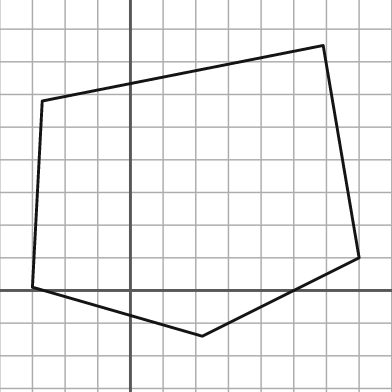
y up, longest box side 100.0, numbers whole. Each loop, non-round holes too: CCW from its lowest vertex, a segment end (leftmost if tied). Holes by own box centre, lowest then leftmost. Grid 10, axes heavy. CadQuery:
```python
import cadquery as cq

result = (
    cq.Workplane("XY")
    .moveTo(22.0, -14.0)
    .lineTo(70.0, 10.0)
    .lineTo(59.0, 75.0)
    .lineTo(-27.0, 58.0)
    .lineTo(-30.0, 1.0)
    .close()
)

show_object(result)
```